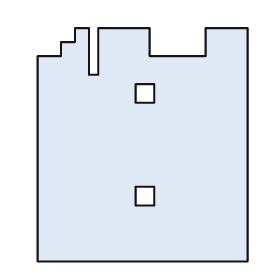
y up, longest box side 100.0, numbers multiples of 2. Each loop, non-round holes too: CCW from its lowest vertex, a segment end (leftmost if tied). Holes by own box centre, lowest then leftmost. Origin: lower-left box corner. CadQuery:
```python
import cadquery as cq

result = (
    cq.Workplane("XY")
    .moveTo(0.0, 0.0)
    .lineTo(90.0, 0.0)
    .lineTo(90.0, 100.0)
    .lineTo(72.0, 100.0)
    .lineTo(72.0, 88.0)
    .lineTo(48.0, 88.0)
    .lineTo(48.0, 100.0)
    .lineTo(26.0, 100.0)
    .lineTo(26.0, 80.0)
    .lineTo(22.0, 80.0)
    .lineTo(22.0, 100.0)
    .lineTo(16.0, 100.0)
    .lineTo(16.0, 94.0)
    .lineTo(10.0, 94.0)
    .lineTo(10.0, 88.0)
    .lineTo(0.0, 88.0)
    .close()
    .moveTo(42.0, 24.0)
    .lineTo(50.0, 24.0)
    .lineTo(50.0, 32.0)
    .lineTo(42.0, 32.0)
    .close()
    .moveTo(42.0, 68.0)
    .lineTo(50.0, 68.0)
    .lineTo(50.0, 76.0)
    .lineTo(42.0, 76.0)
    .close()
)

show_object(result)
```